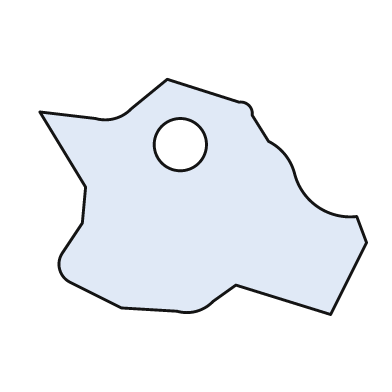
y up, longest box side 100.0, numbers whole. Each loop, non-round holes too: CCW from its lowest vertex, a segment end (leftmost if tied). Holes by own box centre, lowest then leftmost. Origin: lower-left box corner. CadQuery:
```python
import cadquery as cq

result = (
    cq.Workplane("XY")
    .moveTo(89.0, 0.0)
    .lineTo(100.0, 22.0)
    .lineTo(97.0, 30.0)
    .threePointArc((85.0, 33.0), (78.0, 43.0))
    .threePointArc((75.0, 49.0), (70.0, 53.0))
    .lineTo(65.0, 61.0)
    .threePointArc((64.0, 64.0), (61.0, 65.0))
    .lineTo(39.0, 72.0)
    .lineTo(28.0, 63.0)
    .threePointArc((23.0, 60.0), (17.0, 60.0))
    .lineTo(0.0, 62.0)
    .lineTo(14.0, 39.0)
    .lineTo(13.0, 28.0)
    .lineTo(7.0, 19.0)
    .threePointArc((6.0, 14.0), (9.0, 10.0))
    .lineTo(25.0, 2.0)
    .lineTo(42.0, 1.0)
    .threePointArc((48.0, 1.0), (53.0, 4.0))
    .lineTo(60.0, 9.0)
    .close()
    .moveTo(43.0, 52.0)
    .circle(8.0)
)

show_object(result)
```